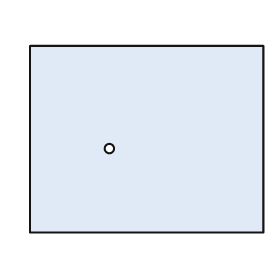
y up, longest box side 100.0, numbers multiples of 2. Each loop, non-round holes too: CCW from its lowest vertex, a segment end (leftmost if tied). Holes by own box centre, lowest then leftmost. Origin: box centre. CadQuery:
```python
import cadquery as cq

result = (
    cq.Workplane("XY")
    .moveTo(-50.0, -40.0)
    .lineTo(50.0, -40.0)
    .lineTo(50.0, 40.0)
    .lineTo(-50.0, 40.0)
    .close()
    .moveTo(-16.0, -4.0)
    .circle(2.0)
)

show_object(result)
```